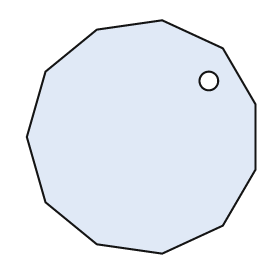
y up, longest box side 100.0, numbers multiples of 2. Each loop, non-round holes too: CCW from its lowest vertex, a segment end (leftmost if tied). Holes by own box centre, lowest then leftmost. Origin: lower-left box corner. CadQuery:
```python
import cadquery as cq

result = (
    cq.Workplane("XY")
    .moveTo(58.0, 0.0)
    .lineTo(84.0, 12.0)
    .lineTo(98.0, 36.0)
    .lineTo(98.0, 64.0)
    .lineTo(84.0, 88.0)
    .lineTo(58.0, 100.0)
    .lineTo(30.0, 96.0)
    .lineTo(8.0, 78.0)
    .lineTo(0.0, 50.0)
    .lineTo(8.0, 22.0)
    .lineTo(30.0, 4.0)
    .close()
    .moveTo(78.0, 74.0)
    .circle(4.0)
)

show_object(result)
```